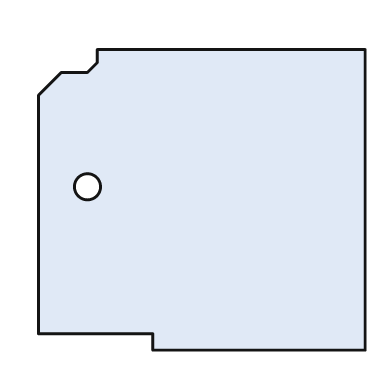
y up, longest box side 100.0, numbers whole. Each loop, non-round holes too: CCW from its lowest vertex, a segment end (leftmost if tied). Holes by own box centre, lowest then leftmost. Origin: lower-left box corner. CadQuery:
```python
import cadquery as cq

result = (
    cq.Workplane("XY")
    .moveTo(35.0, 0.0)
    .lineTo(100.0, 0.0)
    .lineTo(100.0, 92.0)
    .lineTo(18.0, 92.0)
    .lineTo(18.0, 88.0)
    .lineTo(15.0, 85.0)
    .lineTo(7.0, 85.0)
    .lineTo(0.0, 78.0)
    .lineTo(0.0, 5.0)
    .lineTo(35.0, 5.0)
    .close()
    .moveTo(15.0, 50.0)
    .circle(4.0)
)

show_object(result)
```